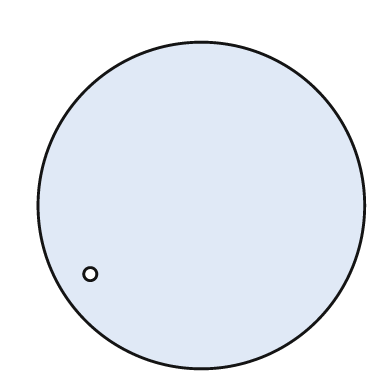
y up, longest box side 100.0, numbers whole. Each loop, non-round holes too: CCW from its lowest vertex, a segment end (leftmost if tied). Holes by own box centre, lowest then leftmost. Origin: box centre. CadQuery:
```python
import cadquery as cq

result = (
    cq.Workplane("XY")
    .moveTo(0.0, 0.0)
    .circle(50.0)
    .moveTo(-34.0, -21.0)
    .circle(2.0)
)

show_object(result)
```